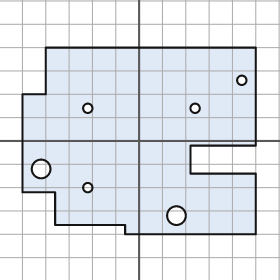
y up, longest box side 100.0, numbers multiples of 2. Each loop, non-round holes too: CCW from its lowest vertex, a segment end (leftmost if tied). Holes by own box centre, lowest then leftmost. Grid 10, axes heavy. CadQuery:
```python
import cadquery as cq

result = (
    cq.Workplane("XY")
    .moveTo(-6.0, -40.0)
    .lineTo(50.0, -40.0)
    .lineTo(50.0, -14.0)
    .lineTo(22.0, -14.0)
    .lineTo(22.0, -2.0)
    .lineTo(50.0, -2.0)
    .lineTo(50.0, 40.0)
    .lineTo(-40.0, 40.0)
    .lineTo(-40.0, 20.0)
    .lineTo(-50.0, 20.0)
    .lineTo(-50.0, -22.0)
    .lineTo(-36.0, -22.0)
    .lineTo(-36.0, -36.0)
    .lineTo(-6.0, -36.0)
    .close()
    .moveTo(16.0, -32.0)
    .circle(4.0)
    .moveTo(-22.0, -20.0)
    .circle(2.0)
    .moveTo(-42.0, -12.0)
    .circle(4.0)
    .moveTo(-22.0, 14.0)
    .circle(2.0)
    .moveTo(24.0, 14.0)
    .circle(2.0)
    .moveTo(44.0, 26.0)
    .circle(2.0)
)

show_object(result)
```